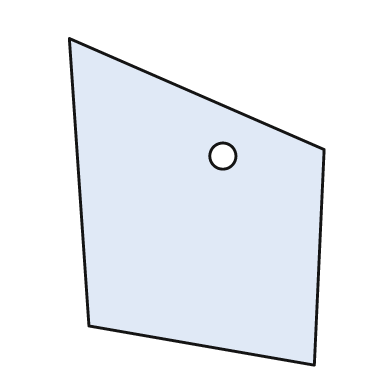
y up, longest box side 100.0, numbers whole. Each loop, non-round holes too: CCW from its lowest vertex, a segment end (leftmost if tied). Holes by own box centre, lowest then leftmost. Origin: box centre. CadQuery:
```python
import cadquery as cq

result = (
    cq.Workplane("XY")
    .moveTo(36.0, -50.0)
    .lineTo(39.0, 16.0)
    .lineTo(-39.0, 50.0)
    .lineTo(-33.0, -38.0)
    .close()
    .moveTo(8.0, 14.0)
    .circle(4.0)
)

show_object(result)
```